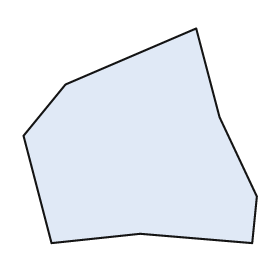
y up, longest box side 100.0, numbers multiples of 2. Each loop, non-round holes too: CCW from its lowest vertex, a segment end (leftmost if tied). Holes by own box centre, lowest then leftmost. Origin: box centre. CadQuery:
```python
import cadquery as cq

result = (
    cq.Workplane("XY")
    .moveTo(-38.0, -46.0)
    .lineTo(0.0, -42.0)
    .lineTo(48.0, -46.0)
    .lineTo(50.0, -26.0)
    .lineTo(34.0, 8.0)
    .lineTo(24.0, 46.0)
    .lineTo(-32.0, 22.0)
    .lineTo(-50.0, 0.0)
    .close()
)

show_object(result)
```